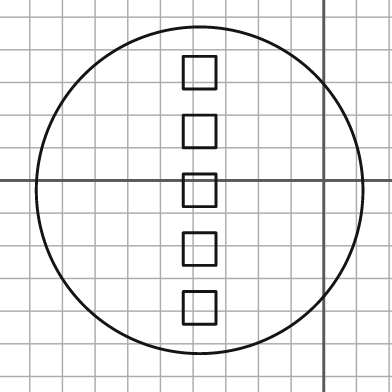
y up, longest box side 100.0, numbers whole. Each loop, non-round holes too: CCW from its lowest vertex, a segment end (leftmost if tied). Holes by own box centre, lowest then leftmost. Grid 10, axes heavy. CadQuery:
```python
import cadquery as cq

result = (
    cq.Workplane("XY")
    .moveTo(-38.0, -3.0)
    .circle(50.0)
    .moveTo(-43.0, -44.0)
    .lineTo(-33.0, -44.0)
    .lineTo(-33.0, -34.0)
    .lineTo(-43.0, -34.0)
    .close()
    .moveTo(-43.0, -26.0)
    .lineTo(-33.0, -26.0)
    .lineTo(-33.0, -16.0)
    .lineTo(-43.0, -16.0)
    .close()
    .moveTo(-43.0, -8.0)
    .lineTo(-33.0, -8.0)
    .lineTo(-33.0, 2.0)
    .lineTo(-43.0, 2.0)
    .close()
    .moveTo(-43.0, 10.0)
    .lineTo(-33.0, 10.0)
    .lineTo(-33.0, 20.0)
    .lineTo(-43.0, 20.0)
    .close()
    .moveTo(-43.0, 28.0)
    .lineTo(-33.0, 28.0)
    .lineTo(-33.0, 38.0)
    .lineTo(-43.0, 38.0)
    .close()
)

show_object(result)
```